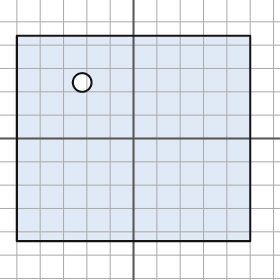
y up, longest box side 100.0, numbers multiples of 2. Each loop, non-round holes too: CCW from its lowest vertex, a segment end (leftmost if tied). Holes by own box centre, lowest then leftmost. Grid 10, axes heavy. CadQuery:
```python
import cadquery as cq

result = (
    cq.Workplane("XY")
    .moveTo(-50.0, -44.0)
    .lineTo(50.0, -44.0)
    .lineTo(50.0, 44.0)
    .lineTo(-50.0, 44.0)
    .close()
    .moveTo(-22.0, 24.0)
    .circle(4.0)
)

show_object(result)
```